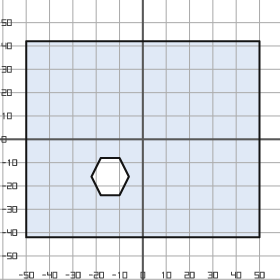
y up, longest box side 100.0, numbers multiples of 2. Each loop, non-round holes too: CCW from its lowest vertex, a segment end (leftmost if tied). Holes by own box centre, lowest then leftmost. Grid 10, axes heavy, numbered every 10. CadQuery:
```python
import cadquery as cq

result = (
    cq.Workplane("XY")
    .moveTo(-50.0, -42.0)
    .lineTo(50.0, -42.0)
    .lineTo(50.0, 42.0)
    .lineTo(-50.0, 42.0)
    .close()
    .moveTo(-18.0, -24.0)
    .lineTo(-10.0, -24.0)
    .lineTo(-6.0, -16.0)
    .lineTo(-10.0, -8.0)
    .lineTo(-18.0, -8.0)
    .lineTo(-22.0, -16.0)
    .close()
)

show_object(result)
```